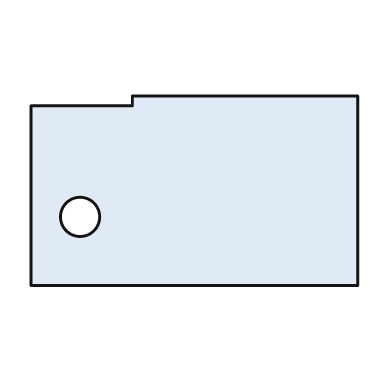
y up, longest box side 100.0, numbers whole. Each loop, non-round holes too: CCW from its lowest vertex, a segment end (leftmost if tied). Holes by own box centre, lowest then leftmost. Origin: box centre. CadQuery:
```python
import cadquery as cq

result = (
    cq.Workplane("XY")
    .moveTo(-50.0, -29.0)
    .lineTo(50.0, -29.0)
    .lineTo(50.0, 29.0)
    .lineTo(-19.0, 29.0)
    .lineTo(-19.0, 26.0)
    .lineTo(-50.0, 26.0)
    .close()
    .moveTo(-35.0, -8.0)
    .circle(6.0)
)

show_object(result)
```